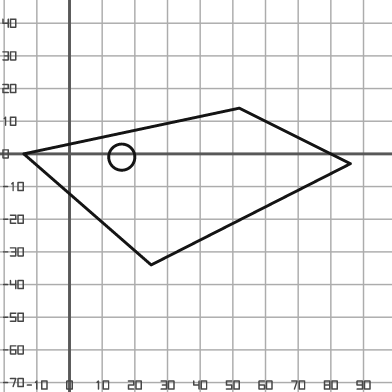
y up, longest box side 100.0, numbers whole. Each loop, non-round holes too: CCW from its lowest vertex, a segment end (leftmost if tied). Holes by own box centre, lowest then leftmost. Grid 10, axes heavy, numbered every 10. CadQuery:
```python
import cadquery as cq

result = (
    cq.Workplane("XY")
    .moveTo(25.0, -34.0)
    .lineTo(86.0, -3.0)
    .lineTo(52.0, 14.0)
    .lineTo(-14.0, 0.0)
    .close()
    .moveTo(16.0, -1.0)
    .circle(4.0)
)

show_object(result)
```